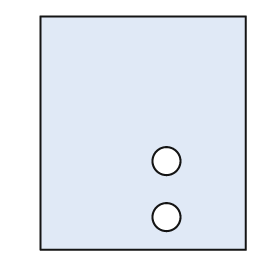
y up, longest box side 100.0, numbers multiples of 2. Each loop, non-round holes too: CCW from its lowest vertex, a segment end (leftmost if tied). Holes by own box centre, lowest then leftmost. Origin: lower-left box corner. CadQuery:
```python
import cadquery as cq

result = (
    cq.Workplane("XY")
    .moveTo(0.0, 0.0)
    .lineTo(88.0, 0.0)
    .lineTo(88.0, 100.0)
    .lineTo(0.0, 100.0)
    .close()
    .moveTo(54.0, 14.0)
    .circle(6.0)
    .moveTo(54.0, 38.0)
    .circle(6.0)
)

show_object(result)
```